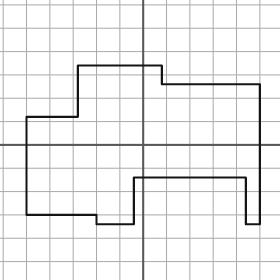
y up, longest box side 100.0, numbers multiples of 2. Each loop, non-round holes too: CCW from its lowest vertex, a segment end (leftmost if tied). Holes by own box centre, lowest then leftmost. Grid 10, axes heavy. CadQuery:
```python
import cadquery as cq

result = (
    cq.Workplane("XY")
    .moveTo(-20.0, -34.0)
    .lineTo(-4.0, -34.0)
    .lineTo(-4.0, -14.0)
    .lineTo(44.0, -14.0)
    .lineTo(44.0, -34.0)
    .lineTo(50.0, -34.0)
    .lineTo(50.0, 26.0)
    .lineTo(8.0, 26.0)
    .lineTo(8.0, 34.0)
    .lineTo(-28.0, 34.0)
    .lineTo(-28.0, 12.0)
    .lineTo(-50.0, 12.0)
    .lineTo(-50.0, -30.0)
    .lineTo(-20.0, -30.0)
    .close()
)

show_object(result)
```